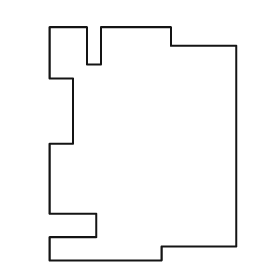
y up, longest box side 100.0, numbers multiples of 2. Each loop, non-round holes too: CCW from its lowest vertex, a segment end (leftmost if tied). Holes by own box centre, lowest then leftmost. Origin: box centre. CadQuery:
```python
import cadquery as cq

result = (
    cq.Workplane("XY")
    .moveTo(-40.0, -50.0)
    .lineTo(8.0, -50.0)
    .lineTo(8.0, -44.0)
    .lineTo(40.0, -44.0)
    .lineTo(40.0, 42.0)
    .lineTo(12.0, 42.0)
    .lineTo(12.0, 50.0)
    .lineTo(-18.0, 50.0)
    .lineTo(-18.0, 34.0)
    .lineTo(-24.0, 34.0)
    .lineTo(-24.0, 50.0)
    .lineTo(-40.0, 50.0)
    .lineTo(-40.0, 28.0)
    .lineTo(-30.0, 28.0)
    .lineTo(-30.0, 0.0)
    .lineTo(-40.0, 0.0)
    .lineTo(-40.0, -30.0)
    .lineTo(-20.0, -30.0)
    .lineTo(-20.0, -40.0)
    .lineTo(-40.0, -40.0)
    .close()
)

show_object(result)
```